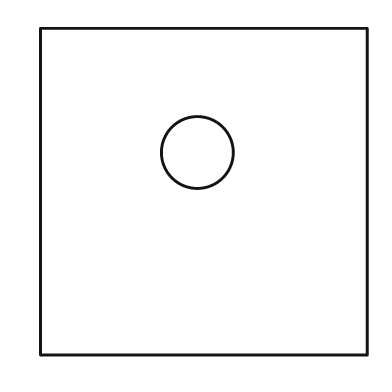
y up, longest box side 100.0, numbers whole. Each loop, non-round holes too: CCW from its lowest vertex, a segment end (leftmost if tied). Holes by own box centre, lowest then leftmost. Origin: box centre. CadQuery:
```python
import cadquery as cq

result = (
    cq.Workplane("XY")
    .moveTo(-50.0, -50.0)
    .lineTo(50.0, -50.0)
    .lineTo(50.0, 50.0)
    .lineTo(-50.0, 50.0)
    .close()
    .moveTo(-2.0, 12.0)
    .circle(11.0)
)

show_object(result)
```